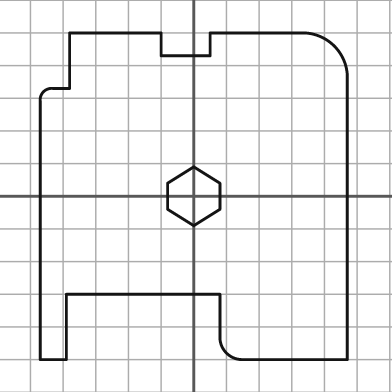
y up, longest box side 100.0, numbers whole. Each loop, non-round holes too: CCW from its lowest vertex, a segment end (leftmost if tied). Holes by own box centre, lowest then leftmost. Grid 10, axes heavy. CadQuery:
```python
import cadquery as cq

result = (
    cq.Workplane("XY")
    .moveTo(-47.0, -50.0)
    .lineTo(-39.0, -50.0)
    .lineTo(-39.0, -30.0)
    .lineTo(8.0, -30.0)
    .lineTo(8.0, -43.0)
    .threePointArc((10.0, -48.0), (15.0, -50.0))
    .lineTo(47.0, -50.0)
    .lineTo(47.0, 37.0)
    .threePointArc((43.0, 46.0), (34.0, 50.0))
    .lineTo(5.0, 50.0)
    .lineTo(5.0, 43.0)
    .lineTo(-10.0, 43.0)
    .lineTo(-10.0, 50.0)
    .lineTo(-38.0, 50.0)
    .lineTo(-38.0, 33.0)
    .lineTo(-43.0, 33.0)
    .threePointArc((-46.0, 32.0), (-47.0, 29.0))
    .close()
    .moveTo(0.0, -9.0)
    .lineTo(8.0, -4.0)
    .lineTo(8.0, 4.0)
    .lineTo(0.0, 9.0)
    .lineTo(-8.0, 4.0)
    .lineTo(-8.0, -4.0)
    .close()
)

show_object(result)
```